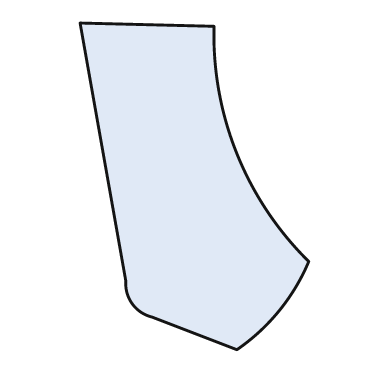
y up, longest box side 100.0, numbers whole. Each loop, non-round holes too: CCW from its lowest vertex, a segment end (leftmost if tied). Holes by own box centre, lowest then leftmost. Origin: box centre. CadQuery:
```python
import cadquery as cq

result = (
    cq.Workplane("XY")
    .moveTo(13.0, -50.0)
    .threePointArc((26.0, -38.0), (35.0, -23.0))
    .threePointArc((13.0, 10.0), (6.0, 49.0))
    .lineTo(-35.0, 50.0)
    .lineTo(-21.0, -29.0)
    .threePointArc((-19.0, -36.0), (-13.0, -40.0))
    .close()
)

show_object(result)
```